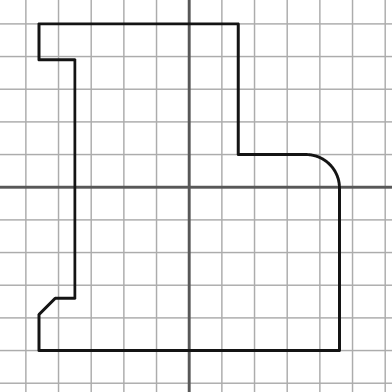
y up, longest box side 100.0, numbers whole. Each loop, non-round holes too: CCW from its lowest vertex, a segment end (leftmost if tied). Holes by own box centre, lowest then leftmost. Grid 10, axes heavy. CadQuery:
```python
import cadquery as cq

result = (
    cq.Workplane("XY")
    .moveTo(-46.0, -50.0)
    .lineTo(46.0, -50.0)
    .lineTo(46.0, 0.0)
    .threePointArc((43.0, 7.0), (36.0, 10.0))
    .lineTo(15.0, 10.0)
    .lineTo(15.0, 50.0)
    .lineTo(-46.0, 50.0)
    .lineTo(-46.0, 39.0)
    .lineTo(-35.0, 39.0)
    .lineTo(-35.0, -34.0)
    .lineTo(-41.0, -34.0)
    .lineTo(-46.0, -39.0)
    .close()
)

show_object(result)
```